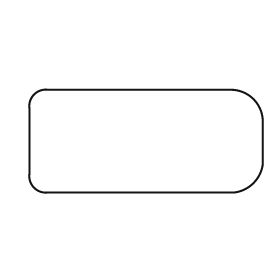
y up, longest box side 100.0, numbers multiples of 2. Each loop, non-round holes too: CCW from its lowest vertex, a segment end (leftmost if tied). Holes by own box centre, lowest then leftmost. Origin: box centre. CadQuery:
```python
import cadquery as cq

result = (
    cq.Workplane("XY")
    .moveTo(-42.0, -22.0)
    .lineTo(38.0, -22.0)
    .threePointArc((46.0, -18.0), (50.0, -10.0))
    .lineTo(50.0, 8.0)
    .threePointArc((46.0, 18.0), (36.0, 22.0))
    .lineTo(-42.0, 22.0)
    .threePointArc((-48.0, 20.0), (-50.0, 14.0))
    .lineTo(-50.0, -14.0)
    .threePointArc((-48.0, -20.0), (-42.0, -22.0))
    .close()
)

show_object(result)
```